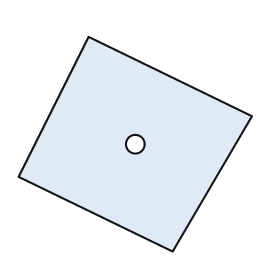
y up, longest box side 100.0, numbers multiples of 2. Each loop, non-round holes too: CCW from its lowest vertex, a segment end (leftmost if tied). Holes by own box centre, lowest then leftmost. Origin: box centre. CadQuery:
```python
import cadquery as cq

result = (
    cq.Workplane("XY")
    .moveTo(16.0, -46.0)
    .lineTo(50.0, 12.0)
    .lineTo(-20.0, 46.0)
    .lineTo(-50.0, -14.0)
    .close()
    .moveTo(0.0, 0.0)
    .circle(4.0)
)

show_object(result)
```